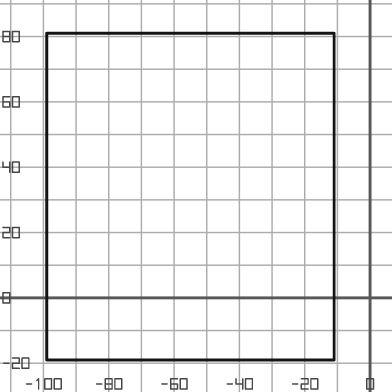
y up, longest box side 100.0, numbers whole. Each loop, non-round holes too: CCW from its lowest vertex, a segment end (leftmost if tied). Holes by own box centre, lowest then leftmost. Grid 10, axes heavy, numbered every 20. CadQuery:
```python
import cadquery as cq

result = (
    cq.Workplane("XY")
    .moveTo(-99.0, -19.0)
    .lineTo(-11.0, -19.0)
    .lineTo(-11.0, 81.0)
    .lineTo(-99.0, 81.0)
    .close()
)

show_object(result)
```